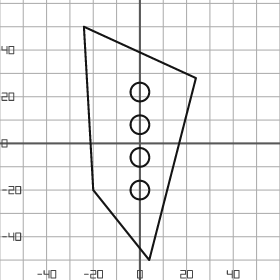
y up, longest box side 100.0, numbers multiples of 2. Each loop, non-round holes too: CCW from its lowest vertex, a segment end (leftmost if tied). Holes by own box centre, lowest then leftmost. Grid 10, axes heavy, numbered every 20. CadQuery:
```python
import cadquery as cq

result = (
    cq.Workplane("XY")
    .moveTo(4.0, -50.0)
    .lineTo(24.0, 28.0)
    .lineTo(-24.0, 50.0)
    .lineTo(-20.0, -20.0)
    .close()
    .moveTo(0.0, -20.0)
    .circle(4.0)
    .moveTo(0.0, -6.0)
    .circle(4.0)
    .moveTo(0.0, 8.0)
    .circle(4.0)
    .moveTo(0.0, 22.0)
    .circle(4.0)
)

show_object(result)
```